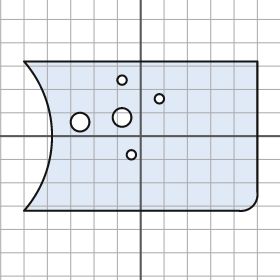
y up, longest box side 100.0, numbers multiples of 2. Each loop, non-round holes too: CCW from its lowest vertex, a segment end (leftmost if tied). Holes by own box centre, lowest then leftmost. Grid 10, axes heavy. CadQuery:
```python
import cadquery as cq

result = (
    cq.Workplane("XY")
    .moveTo(-50.0, -32.0)
    .lineTo(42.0, -32.0)
    .threePointArc((48.0, -30.0), (50.0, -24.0))
    .lineTo(50.0, 32.0)
    .lineTo(-50.0, 32.0)
    .threePointArc((-38.0, 0.0), (-50.0, -32.0))
    .close()
    .moveTo(-4.0, -8.0)
    .circle(2.0)
    .moveTo(-26.0, 6.0)
    .circle(4.0)
    .moveTo(-8.0, 8.0)
    .circle(4.0)
    .moveTo(8.0, 16.0)
    .circle(2.0)
    .moveTo(-8.0, 24.0)
    .circle(2.0)
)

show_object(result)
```